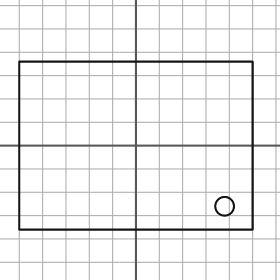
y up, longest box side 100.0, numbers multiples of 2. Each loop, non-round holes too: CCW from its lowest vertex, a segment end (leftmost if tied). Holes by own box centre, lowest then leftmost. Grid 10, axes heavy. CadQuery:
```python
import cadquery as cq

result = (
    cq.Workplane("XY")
    .moveTo(-50.0, -36.0)
    .lineTo(50.0, -36.0)
    .lineTo(50.0, 36.0)
    .lineTo(-50.0, 36.0)
    .close()
    .moveTo(38.0, -26.0)
    .circle(4.0)
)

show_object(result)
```